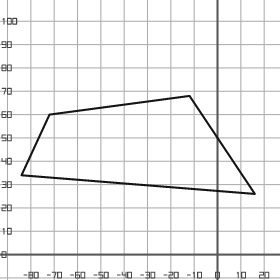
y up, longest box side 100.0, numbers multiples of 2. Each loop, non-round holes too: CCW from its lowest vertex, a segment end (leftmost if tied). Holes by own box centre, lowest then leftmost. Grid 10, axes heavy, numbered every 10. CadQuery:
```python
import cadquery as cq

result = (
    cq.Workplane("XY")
    .moveTo(16.0, 26.0)
    .lineTo(-12.0, 68.0)
    .lineTo(-72.0, 60.0)
    .lineTo(-84.0, 34.0)
    .close()
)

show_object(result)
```